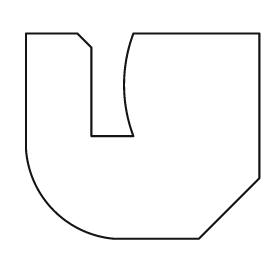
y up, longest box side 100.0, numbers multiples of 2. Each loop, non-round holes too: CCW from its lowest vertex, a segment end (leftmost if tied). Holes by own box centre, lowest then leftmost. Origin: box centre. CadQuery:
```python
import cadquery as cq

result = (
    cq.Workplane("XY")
    .moveTo(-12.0, -44.0)
    .lineTo(24.0, -44.0)
    .lineTo(50.0, -18.0)
    .lineTo(50.0, 44.0)
    .lineTo(-4.0, 44.0)
    .threePointArc((-8.0, 22.0), (-4.0, 0.0))
    .lineTo(-22.0, 0.0)
    .lineTo(-22.0, 38.0)
    .lineTo(-28.0, 44.0)
    .lineTo(-50.0, 44.0)
    .lineTo(-50.0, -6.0)
    .threePointArc((-38.0, -32.0), (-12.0, -44.0))
    .close()
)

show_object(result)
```